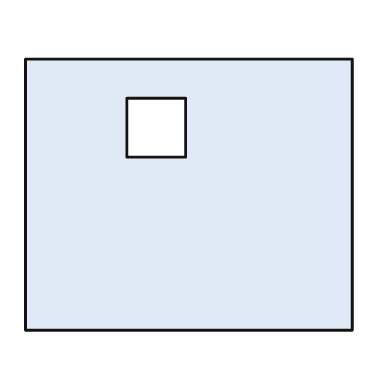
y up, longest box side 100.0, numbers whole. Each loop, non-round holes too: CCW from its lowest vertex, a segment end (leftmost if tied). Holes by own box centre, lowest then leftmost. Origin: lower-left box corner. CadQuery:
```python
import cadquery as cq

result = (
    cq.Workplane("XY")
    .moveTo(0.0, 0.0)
    .lineTo(100.0, 0.0)
    .lineTo(100.0, 83.0)
    .lineTo(0.0, 83.0)
    .close()
    .moveTo(31.0, 53.0)
    .lineTo(49.0, 53.0)
    .lineTo(49.0, 71.0)
    .lineTo(31.0, 71.0)
    .close()
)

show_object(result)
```